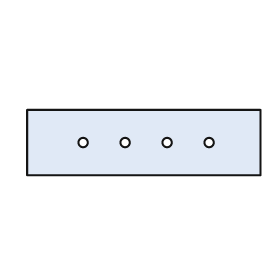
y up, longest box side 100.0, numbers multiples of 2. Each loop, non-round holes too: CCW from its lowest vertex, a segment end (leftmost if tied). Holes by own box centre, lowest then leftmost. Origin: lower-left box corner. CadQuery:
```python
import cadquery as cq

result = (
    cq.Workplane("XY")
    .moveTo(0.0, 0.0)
    .lineTo(100.0, 0.0)
    .lineTo(100.0, 28.0)
    .lineTo(0.0, 28.0)
    .close()
    .moveTo(24.0, 14.0)
    .circle(2.0)
    .moveTo(42.0, 14.0)
    .circle(2.0)
    .moveTo(60.0, 14.0)
    .circle(2.0)
    .moveTo(78.0, 14.0)
    .circle(2.0)
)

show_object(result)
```